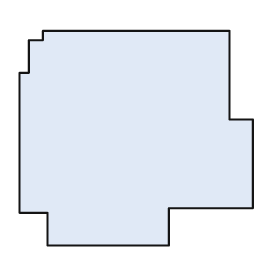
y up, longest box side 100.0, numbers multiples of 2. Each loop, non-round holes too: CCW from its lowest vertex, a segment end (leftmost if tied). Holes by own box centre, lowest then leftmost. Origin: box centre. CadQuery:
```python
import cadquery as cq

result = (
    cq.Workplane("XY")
    .moveTo(-38.0, -46.0)
    .lineTo(14.0, -46.0)
    .lineTo(14.0, -30.0)
    .lineTo(50.0, -30.0)
    .lineTo(50.0, 8.0)
    .lineTo(40.0, 8.0)
    .lineTo(40.0, 46.0)
    .lineTo(-40.0, 46.0)
    .lineTo(-40.0, 42.0)
    .lineTo(-46.0, 42.0)
    .lineTo(-46.0, 28.0)
    .lineTo(-50.0, 28.0)
    .lineTo(-50.0, -32.0)
    .lineTo(-38.0, -32.0)
    .close()
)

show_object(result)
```